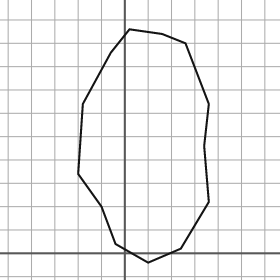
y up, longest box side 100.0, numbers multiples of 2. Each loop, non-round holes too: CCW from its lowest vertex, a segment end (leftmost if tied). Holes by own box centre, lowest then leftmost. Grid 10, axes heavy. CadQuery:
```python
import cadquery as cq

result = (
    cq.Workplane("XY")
    .moveTo(10.0, -4.0)
    .lineTo(24.0, 2.0)
    .lineTo(36.0, 22.0)
    .lineTo(34.0, 46.0)
    .lineTo(36.0, 64.0)
    .lineTo(26.0, 90.0)
    .lineTo(16.0, 94.0)
    .lineTo(2.0, 96.0)
    .lineTo(-6.0, 86.0)
    .lineTo(-18.0, 64.0)
    .lineTo(-20.0, 34.0)
    .lineTo(-10.0, 20.0)
    .lineTo(-4.0, 4.0)
    .close()
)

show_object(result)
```